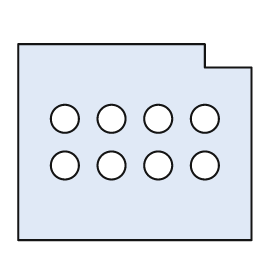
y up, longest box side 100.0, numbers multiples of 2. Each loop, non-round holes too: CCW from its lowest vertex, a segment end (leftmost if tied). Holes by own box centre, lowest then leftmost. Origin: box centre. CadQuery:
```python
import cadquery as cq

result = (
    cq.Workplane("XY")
    .moveTo(-50.0, -42.0)
    .lineTo(50.0, -42.0)
    .lineTo(50.0, 32.0)
    .lineTo(30.0, 32.0)
    .lineTo(30.0, 42.0)
    .lineTo(-50.0, 42.0)
    .close()
    .moveTo(-30.0, -10.0)
    .circle(6.0)
    .moveTo(-10.0, -10.0)
    .circle(6.0)
    .moveTo(10.0, -10.0)
    .circle(6.0)
    .moveTo(30.0, -10.0)
    .circle(6.0)
    .moveTo(-30.0, 10.0)
    .circle(6.0)
    .moveTo(-10.0, 10.0)
    .circle(6.0)
    .moveTo(10.0, 10.0)
    .circle(6.0)
    .moveTo(30.0, 10.0)
    .circle(6.0)
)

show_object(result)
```